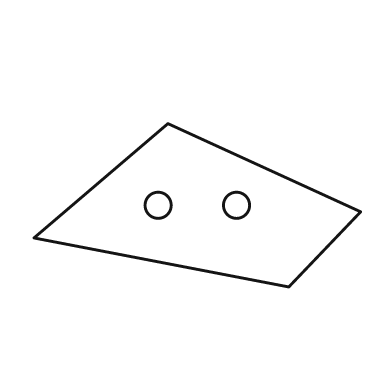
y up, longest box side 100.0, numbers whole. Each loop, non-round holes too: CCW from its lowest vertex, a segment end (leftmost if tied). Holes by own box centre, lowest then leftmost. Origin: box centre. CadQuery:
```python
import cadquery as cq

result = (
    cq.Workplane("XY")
    .moveTo(28.0, -25.0)
    .lineTo(50.0, -2.0)
    .lineTo(-9.0, 25.0)
    .lineTo(-50.0, -10.0)
    .close()
    .moveTo(-12.0, 0.0)
    .circle(4.0)
    .moveTo(12.0, 0.0)
    .circle(4.0)
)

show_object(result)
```